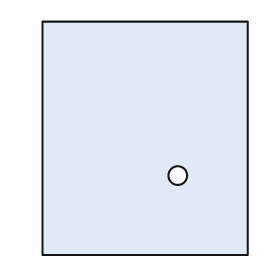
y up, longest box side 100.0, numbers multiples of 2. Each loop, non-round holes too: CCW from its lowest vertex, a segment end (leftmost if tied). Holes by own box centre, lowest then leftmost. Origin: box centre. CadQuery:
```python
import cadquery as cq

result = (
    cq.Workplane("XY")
    .moveTo(-44.0, -50.0)
    .lineTo(44.0, -50.0)
    .lineTo(44.0, 50.0)
    .lineTo(-44.0, 50.0)
    .close()
    .moveTo(14.0, -16.0)
    .circle(4.0)
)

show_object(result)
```